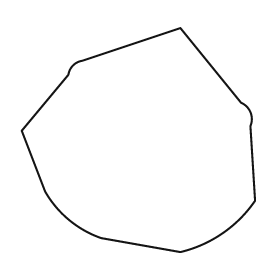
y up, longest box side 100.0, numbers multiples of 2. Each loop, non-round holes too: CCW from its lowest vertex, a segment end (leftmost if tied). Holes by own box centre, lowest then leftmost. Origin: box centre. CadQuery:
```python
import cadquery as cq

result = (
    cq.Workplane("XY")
    .moveTo(18.0, -48.0)
    .threePointArc((36.0, -40.0), (50.0, -26.0))
    .lineTo(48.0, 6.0)
    .threePointArc((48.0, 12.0), (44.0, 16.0))
    .lineTo(18.0, 48.0)
    .lineTo(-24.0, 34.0)
    .threePointArc((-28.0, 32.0), (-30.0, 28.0))
    .lineTo(-50.0, 4.0)
    .lineTo(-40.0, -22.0)
    .threePointArc((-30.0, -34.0), (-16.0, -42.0))
    .close()
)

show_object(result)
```